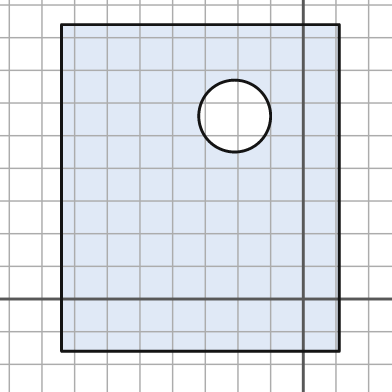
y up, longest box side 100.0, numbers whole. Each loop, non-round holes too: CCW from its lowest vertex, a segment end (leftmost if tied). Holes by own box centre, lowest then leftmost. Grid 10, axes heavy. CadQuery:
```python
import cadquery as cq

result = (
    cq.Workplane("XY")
    .moveTo(-74.0, -16.0)
    .lineTo(11.0, -16.0)
    .lineTo(11.0, 84.0)
    .lineTo(-74.0, 84.0)
    .close()
    .moveTo(-21.0, 56.0)
    .circle(11.0)
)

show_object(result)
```